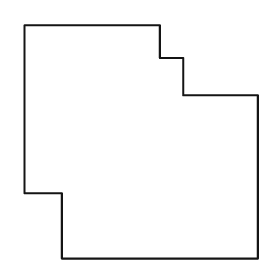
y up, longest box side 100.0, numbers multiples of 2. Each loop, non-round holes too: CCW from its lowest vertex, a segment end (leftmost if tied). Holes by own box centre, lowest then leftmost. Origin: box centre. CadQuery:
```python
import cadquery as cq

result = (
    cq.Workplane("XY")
    .moveTo(-34.0, -50.0)
    .lineTo(50.0, -50.0)
    .lineTo(50.0, 20.0)
    .lineTo(18.0, 20.0)
    .lineTo(18.0, 36.0)
    .lineTo(8.0, 36.0)
    .lineTo(8.0, 50.0)
    .lineTo(-50.0, 50.0)
    .lineTo(-50.0, -22.0)
    .lineTo(-34.0, -22.0)
    .close()
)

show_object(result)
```